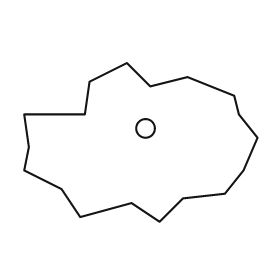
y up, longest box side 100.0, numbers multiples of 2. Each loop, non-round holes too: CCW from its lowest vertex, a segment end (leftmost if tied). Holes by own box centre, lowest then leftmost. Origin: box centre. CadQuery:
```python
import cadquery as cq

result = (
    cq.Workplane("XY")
    .moveTo(8.0, -34.0)
    .lineTo(18.0, -24.0)
    .lineTo(36.0, -22.0)
    .lineTo(44.0, -12.0)
    .lineTo(50.0, 2.0)
    .lineTo(42.0, 12.0)
    .lineTo(40.0, 20.0)
    .lineTo(20.0, 28.0)
    .lineTo(4.0, 24.0)
    .lineTo(-6.0, 34.0)
    .lineTo(-22.0, 26.0)
    .lineTo(-24.0, 12.0)
    .lineTo(-50.0, 12.0)
    .lineTo(-48.0, -2.0)
    .lineTo(-50.0, -12.0)
    .lineTo(-34.0, -20.0)
    .lineTo(-26.0, -32.0)
    .lineTo(-4.0, -26.0)
    .close()
    .moveTo(2.0, 6.0)
    .circle(4.0)
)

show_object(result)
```